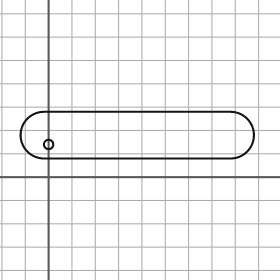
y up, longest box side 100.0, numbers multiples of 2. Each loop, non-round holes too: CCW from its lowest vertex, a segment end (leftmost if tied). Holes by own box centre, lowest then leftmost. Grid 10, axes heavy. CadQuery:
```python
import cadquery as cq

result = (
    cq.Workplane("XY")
    .moveTo(-2.0, 8.0)
    .lineTo(78.0, 8.0)
    .threePointArc((88.0, 18.0), (78.0, 28.0))
    .lineTo(-2.0, 28.0)
    .threePointArc((-12.0, 18.0), (-2.0, 8.0))
    .close()
    .moveTo(0.0, 14.0)
    .circle(2.0)
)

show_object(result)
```